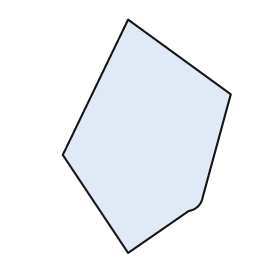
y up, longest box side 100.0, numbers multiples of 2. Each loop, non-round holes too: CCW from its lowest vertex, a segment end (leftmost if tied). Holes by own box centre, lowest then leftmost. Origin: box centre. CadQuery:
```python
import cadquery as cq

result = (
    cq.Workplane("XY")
    .moveTo(-8.0, -50.0)
    .lineTo(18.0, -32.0)
    .threePointArc((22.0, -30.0), (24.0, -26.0))
    .lineTo(36.0, 18.0)
    .lineTo(-8.0, 50.0)
    .lineTo(-36.0, -8.0)
    .close()
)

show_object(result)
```